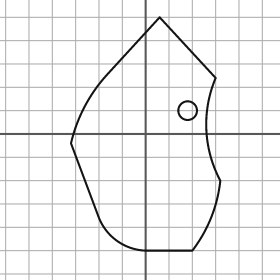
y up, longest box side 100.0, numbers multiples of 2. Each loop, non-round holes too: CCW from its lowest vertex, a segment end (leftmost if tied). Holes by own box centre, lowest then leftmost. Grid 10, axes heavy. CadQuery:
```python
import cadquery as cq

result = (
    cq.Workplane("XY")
    .moveTo(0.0, -50.0)
    .lineTo(20.0, -50.0)
    .threePointArc((28.0, -36.0), (32.0, -20.0))
    .threePointArc((26.0, 2.0), (30.0, 24.0))
    .lineTo(6.0, 50.0)
    .lineTo(-16.0, 26.0)
    .threePointArc((-26.0, 12.0), (-32.0, -4.0))
    .lineTo(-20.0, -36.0)
    .threePointArc((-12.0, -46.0), (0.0, -50.0))
    .close()
    .moveTo(18.0, 10.0)
    .circle(4.0)
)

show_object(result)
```